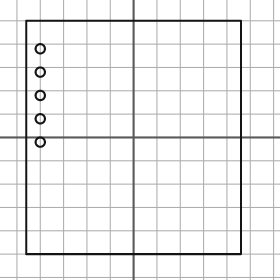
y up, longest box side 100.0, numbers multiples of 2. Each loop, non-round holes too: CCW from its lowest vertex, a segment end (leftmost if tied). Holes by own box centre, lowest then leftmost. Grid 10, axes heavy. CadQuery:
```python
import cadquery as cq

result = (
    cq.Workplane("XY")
    .moveTo(-46.0, -50.0)
    .lineTo(46.0, -50.0)
    .lineTo(46.0, 50.0)
    .lineTo(-46.0, 50.0)
    .close()
    .moveTo(-40.0, -2.0)
    .circle(2.0)
    .moveTo(-40.0, 8.0)
    .circle(2.0)
    .moveTo(-40.0, 18.0)
    .circle(2.0)
    .moveTo(-40.0, 28.0)
    .circle(2.0)
    .moveTo(-40.0, 38.0)
    .circle(2.0)
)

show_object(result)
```